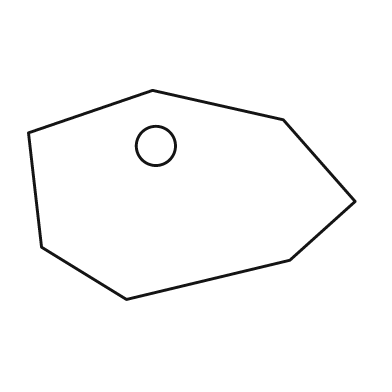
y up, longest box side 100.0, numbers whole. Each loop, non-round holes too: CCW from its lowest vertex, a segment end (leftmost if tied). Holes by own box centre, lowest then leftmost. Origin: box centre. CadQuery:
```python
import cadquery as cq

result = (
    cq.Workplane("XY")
    .moveTo(-20.0, -32.0)
    .lineTo(30.0, -20.0)
    .lineTo(50.0, -2.0)
    .lineTo(28.0, 23.0)
    .lineTo(-12.0, 32.0)
    .lineTo(-50.0, 19.0)
    .lineTo(-46.0, -16.0)
    .close()
    .moveTo(-11.0, 15.0)
    .circle(6.0)
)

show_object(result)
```